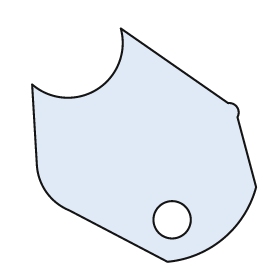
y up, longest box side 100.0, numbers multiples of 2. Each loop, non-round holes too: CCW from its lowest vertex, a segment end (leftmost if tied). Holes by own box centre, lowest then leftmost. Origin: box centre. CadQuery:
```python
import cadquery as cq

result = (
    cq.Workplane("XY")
    .moveTo(10.0, -50.0)
    .threePointArc((34.0, -40.0), (48.0, -18.0))
    .lineTo(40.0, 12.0)
    .threePointArc((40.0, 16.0), (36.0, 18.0))
    .lineTo(-10.0, 50.0)
    .threePointArc((-20.0, 24.0), (-48.0, 26.0))
    .lineTo(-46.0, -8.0)
    .threePointArc((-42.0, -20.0), (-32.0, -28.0))
    .close()
    .moveTo(12.0, -32.0)
    .circle(8.0)
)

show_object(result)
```